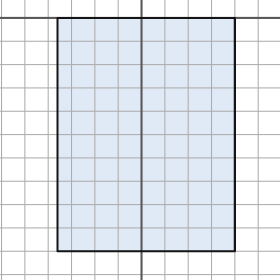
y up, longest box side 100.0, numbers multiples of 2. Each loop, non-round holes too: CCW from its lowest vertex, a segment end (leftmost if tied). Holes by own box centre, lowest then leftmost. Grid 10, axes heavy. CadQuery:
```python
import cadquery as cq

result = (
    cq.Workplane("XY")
    .moveTo(-36.0, -100.0)
    .lineTo(40.0, -100.0)
    .lineTo(40.0, 0.0)
    .lineTo(-36.0, 0.0)
    .close()
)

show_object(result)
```